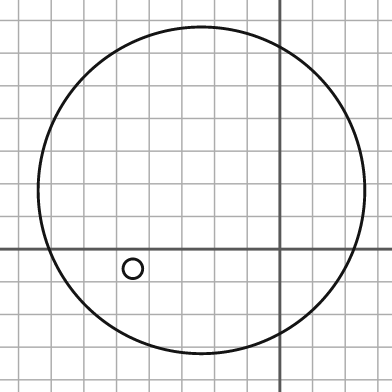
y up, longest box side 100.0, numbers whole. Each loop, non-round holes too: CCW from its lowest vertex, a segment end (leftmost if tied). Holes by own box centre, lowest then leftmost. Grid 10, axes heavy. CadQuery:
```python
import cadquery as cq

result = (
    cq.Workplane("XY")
    .moveTo(-24.0, 18.0)
    .circle(50.0)
    .moveTo(-45.0, -6.0)
    .circle(3.0)
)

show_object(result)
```